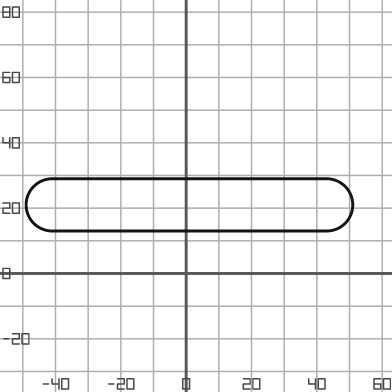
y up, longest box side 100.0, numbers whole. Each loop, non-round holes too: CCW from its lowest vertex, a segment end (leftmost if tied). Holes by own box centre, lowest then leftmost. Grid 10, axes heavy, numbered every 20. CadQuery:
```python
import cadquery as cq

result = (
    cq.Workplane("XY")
    .moveTo(-41.0, 13.0)
    .lineTo(43.0, 13.0)
    .threePointArc((51.0, 21.0), (43.0, 29.0))
    .lineTo(-41.0, 29.0)
    .threePointArc((-49.0, 21.0), (-41.0, 13.0))
    .close()
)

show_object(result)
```